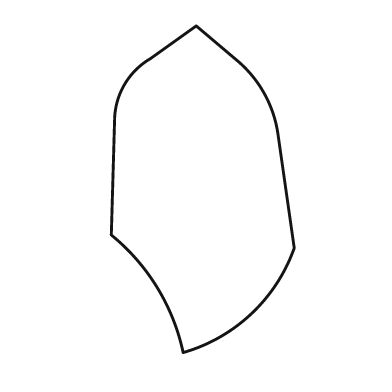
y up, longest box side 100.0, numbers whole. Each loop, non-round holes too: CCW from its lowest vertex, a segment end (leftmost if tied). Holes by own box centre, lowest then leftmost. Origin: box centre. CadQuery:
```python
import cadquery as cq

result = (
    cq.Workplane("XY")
    .moveTo(-6.0, -50.0)
    .threePointArc((15.0, -38.0), (28.0, -18.0))
    .lineTo(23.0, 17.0)
    .threePointArc((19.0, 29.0), (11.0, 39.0))
    .lineTo(-2.0, 50.0)
    .lineTo(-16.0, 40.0)
    .threePointArc((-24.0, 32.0), (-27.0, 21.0))
    .lineTo(-28.0, -14.0)
    .threePointArc((-14.0, -30.0), (-6.0, -50.0))
    .close()
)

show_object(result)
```